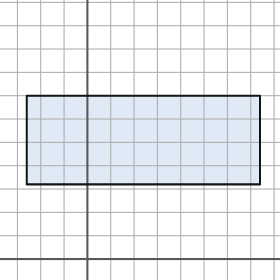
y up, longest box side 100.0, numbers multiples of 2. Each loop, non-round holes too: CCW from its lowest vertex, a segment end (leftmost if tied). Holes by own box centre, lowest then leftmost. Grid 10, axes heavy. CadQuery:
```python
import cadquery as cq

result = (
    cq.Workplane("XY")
    .moveTo(-26.0, 32.0)
    .lineTo(74.0, 32.0)
    .lineTo(74.0, 70.0)
    .lineTo(-26.0, 70.0)
    .close()
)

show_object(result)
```